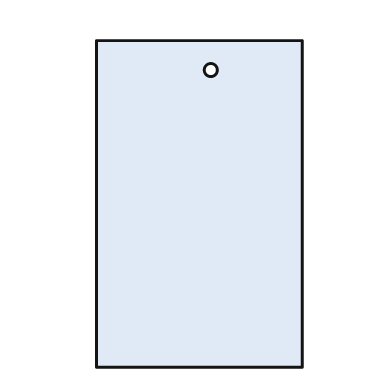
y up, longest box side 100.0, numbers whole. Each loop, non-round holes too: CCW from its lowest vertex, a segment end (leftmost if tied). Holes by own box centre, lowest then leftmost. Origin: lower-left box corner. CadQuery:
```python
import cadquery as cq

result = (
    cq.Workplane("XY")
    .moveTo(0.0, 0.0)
    .lineTo(63.0, 0.0)
    .lineTo(63.0, 100.0)
    .lineTo(0.0, 100.0)
    .close()
    .moveTo(35.0, 91.0)
    .circle(2.0)
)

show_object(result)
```